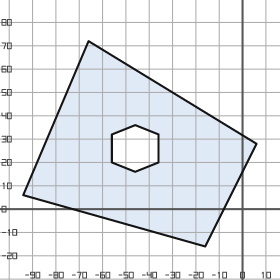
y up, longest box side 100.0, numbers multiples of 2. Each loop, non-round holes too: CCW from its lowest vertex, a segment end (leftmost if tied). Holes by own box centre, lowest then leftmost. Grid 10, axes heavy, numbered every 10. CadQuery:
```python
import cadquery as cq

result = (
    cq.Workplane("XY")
    .moveTo(-16.0, -16.0)
    .lineTo(6.0, 28.0)
    .lineTo(-66.0, 72.0)
    .lineTo(-94.0, 6.0)
    .close()
    .moveTo(-46.0, 16.0)
    .lineTo(-36.0, 20.0)
    .lineTo(-36.0, 32.0)
    .lineTo(-46.0, 36.0)
    .lineTo(-56.0, 32.0)
    .lineTo(-56.0, 20.0)
    .close()
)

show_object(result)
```